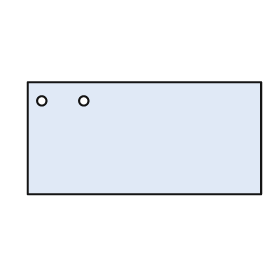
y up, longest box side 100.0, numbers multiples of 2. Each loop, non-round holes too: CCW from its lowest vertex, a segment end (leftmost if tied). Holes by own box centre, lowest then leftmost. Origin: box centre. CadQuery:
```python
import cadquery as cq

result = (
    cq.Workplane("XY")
    .moveTo(-50.0, -24.0)
    .lineTo(50.0, -24.0)
    .lineTo(50.0, 24.0)
    .lineTo(-50.0, 24.0)
    .close()
    .moveTo(-44.0, 16.0)
    .circle(2.0)
    .moveTo(-26.0, 16.0)
    .circle(2.0)
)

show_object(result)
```